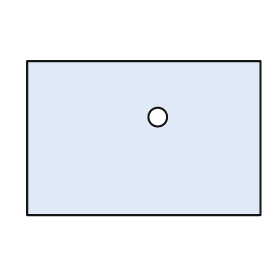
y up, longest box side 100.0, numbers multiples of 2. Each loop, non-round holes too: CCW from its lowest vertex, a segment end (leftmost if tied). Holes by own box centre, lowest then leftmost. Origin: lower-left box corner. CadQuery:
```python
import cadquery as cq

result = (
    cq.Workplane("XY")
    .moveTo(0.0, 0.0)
    .lineTo(100.0, 0.0)
    .lineTo(100.0, 66.0)
    .lineTo(0.0, 66.0)
    .close()
    .moveTo(56.0, 42.0)
    .circle(4.0)
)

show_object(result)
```